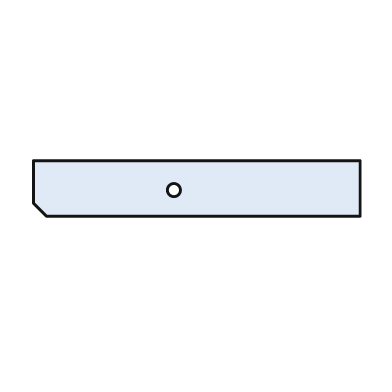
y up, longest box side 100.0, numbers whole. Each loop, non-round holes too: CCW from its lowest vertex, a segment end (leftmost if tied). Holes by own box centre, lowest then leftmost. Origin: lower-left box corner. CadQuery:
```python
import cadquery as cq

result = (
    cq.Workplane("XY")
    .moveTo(4.0, 0.0)
    .lineTo(100.0, 0.0)
    .lineTo(100.0, 17.0)
    .lineTo(0.0, 17.0)
    .lineTo(0.0, 4.0)
    .close()
    .moveTo(43.0, 8.0)
    .circle(2.0)
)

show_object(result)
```